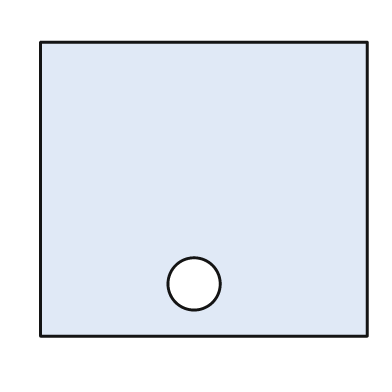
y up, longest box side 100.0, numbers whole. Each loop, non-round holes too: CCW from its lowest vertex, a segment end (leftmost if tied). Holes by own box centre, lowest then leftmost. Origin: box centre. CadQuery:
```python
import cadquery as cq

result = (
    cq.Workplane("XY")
    .moveTo(-50.0, -45.0)
    .lineTo(50.0, -45.0)
    .lineTo(50.0, 45.0)
    .lineTo(-50.0, 45.0)
    .close()
    .moveTo(-3.0, -29.0)
    .circle(8.0)
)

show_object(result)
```